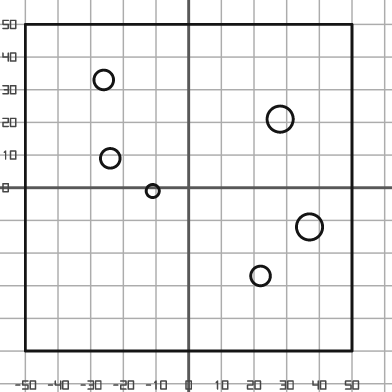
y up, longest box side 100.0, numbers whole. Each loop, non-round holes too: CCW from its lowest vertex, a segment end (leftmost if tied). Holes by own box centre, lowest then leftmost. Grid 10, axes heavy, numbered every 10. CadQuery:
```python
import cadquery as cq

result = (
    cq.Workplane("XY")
    .moveTo(-50.0, -50.0)
    .lineTo(50.0, -50.0)
    .lineTo(50.0, 50.0)
    .lineTo(-50.0, 50.0)
    .close()
    .moveTo(22.0, -27.0)
    .circle(3.0)
    .moveTo(37.0, -12.0)
    .circle(4.0)
    .moveTo(-11.0, -1.0)
    .circle(2.0)
    .moveTo(-24.0, 9.0)
    .circle(3.0)
    .moveTo(28.0, 21.0)
    .circle(4.0)
    .moveTo(-26.0, 33.0)
    .circle(3.0)
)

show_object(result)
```